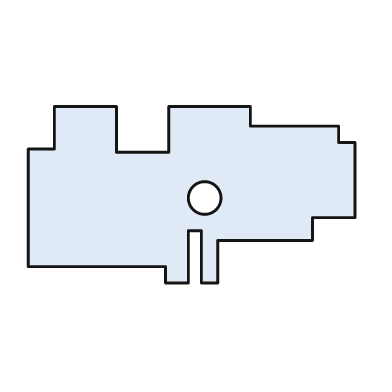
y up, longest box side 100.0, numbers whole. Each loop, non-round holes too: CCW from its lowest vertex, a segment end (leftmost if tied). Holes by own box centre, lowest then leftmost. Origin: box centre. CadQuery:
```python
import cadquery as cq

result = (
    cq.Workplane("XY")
    .moveTo(-8.0, -27.0)
    .lineTo(-1.0, -27.0)
    .lineTo(-1.0, -11.0)
    .lineTo(3.0, -11.0)
    .lineTo(3.0, -27.0)
    .lineTo(8.0, -27.0)
    .lineTo(8.0, -14.0)
    .lineTo(37.0, -14.0)
    .lineTo(37.0, -7.0)
    .lineTo(50.0, -7.0)
    .lineTo(50.0, 16.0)
    .lineTo(45.0, 16.0)
    .lineTo(45.0, 21.0)
    .lineTo(18.0, 21.0)
    .lineTo(18.0, 27.0)
    .lineTo(-7.0, 27.0)
    .lineTo(-7.0, 13.0)
    .lineTo(-23.0, 13.0)
    .lineTo(-23.0, 27.0)
    .lineTo(-42.0, 27.0)
    .lineTo(-42.0, 14.0)
    .lineTo(-50.0, 14.0)
    .lineTo(-50.0, -22.0)
    .lineTo(-8.0, -22.0)
    .close()
    .moveTo(4.0, -1.0)
    .circle(5.0)
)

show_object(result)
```